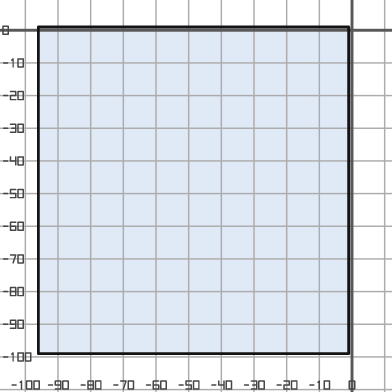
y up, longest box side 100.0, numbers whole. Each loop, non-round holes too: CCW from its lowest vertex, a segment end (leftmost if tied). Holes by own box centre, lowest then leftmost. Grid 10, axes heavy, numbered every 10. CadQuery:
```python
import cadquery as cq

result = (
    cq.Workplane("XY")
    .moveTo(-96.0, -99.0)
    .lineTo(-1.0, -99.0)
    .lineTo(-1.0, 1.0)
    .lineTo(-96.0, 1.0)
    .close()
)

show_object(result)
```